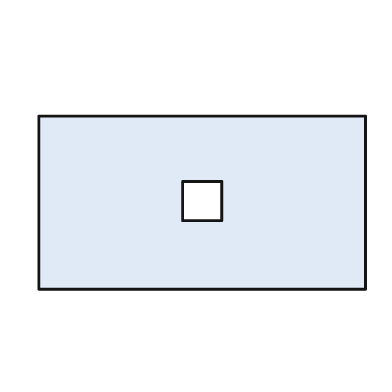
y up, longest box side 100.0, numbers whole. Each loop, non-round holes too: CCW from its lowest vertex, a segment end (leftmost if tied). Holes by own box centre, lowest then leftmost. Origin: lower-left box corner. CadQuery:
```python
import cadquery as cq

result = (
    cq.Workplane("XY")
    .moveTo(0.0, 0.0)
    .lineTo(100.0, 0.0)
    .lineTo(100.0, 53.0)
    .lineTo(0.0, 53.0)
    .close()
    .moveTo(44.0, 21.0)
    .lineTo(56.0, 21.0)
    .lineTo(56.0, 33.0)
    .lineTo(44.0, 33.0)
    .close()
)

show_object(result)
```